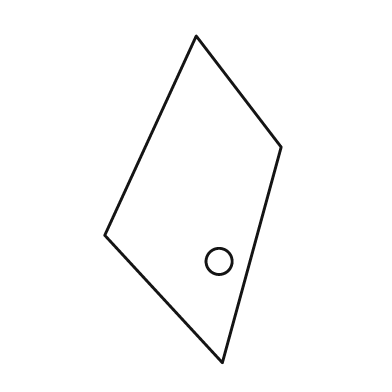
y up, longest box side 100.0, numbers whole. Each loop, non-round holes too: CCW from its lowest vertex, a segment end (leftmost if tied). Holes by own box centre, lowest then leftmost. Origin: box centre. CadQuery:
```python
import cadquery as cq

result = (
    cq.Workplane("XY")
    .moveTo(9.0, -50.0)
    .lineTo(27.0, 16.0)
    .lineTo(1.0, 50.0)
    .lineTo(-27.0, -11.0)
    .close()
    .moveTo(8.0, -19.0)
    .circle(4.0)
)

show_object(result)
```